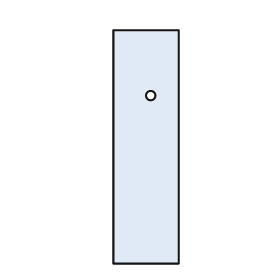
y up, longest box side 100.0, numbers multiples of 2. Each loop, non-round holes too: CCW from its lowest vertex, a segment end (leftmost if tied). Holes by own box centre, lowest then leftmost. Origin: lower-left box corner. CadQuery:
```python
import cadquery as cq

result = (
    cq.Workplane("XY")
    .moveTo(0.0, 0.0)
    .lineTo(28.0, 0.0)
    .lineTo(28.0, 100.0)
    .lineTo(0.0, 100.0)
    .close()
    .moveTo(16.0, 72.0)
    .circle(2.0)
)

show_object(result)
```